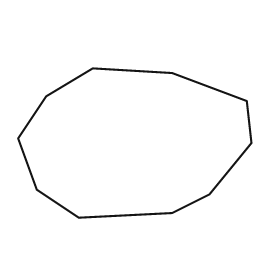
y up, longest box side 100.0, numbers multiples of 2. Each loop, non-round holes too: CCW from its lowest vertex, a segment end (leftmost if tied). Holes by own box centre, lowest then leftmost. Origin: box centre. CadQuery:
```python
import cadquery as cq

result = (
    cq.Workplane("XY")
    .moveTo(-24.0, -32.0)
    .lineTo(16.0, -30.0)
    .lineTo(32.0, -22.0)
    .lineTo(50.0, 0.0)
    .lineTo(48.0, 18.0)
    .lineTo(16.0, 30.0)
    .lineTo(-18.0, 32.0)
    .lineTo(-38.0, 20.0)
    .lineTo(-50.0, 2.0)
    .lineTo(-42.0, -20.0)
    .close()
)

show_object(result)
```